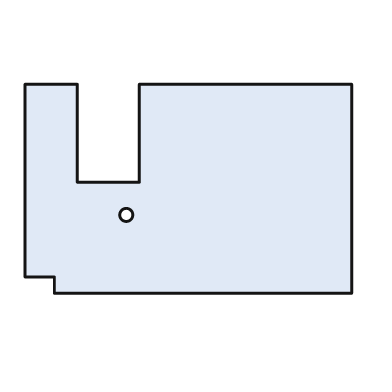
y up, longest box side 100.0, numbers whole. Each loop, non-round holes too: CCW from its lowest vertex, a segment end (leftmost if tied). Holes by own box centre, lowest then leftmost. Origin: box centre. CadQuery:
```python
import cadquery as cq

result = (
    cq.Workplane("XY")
    .moveTo(-41.0, -32.0)
    .lineTo(50.0, -32.0)
    .lineTo(50.0, 32.0)
    .lineTo(-15.0, 32.0)
    .lineTo(-15.0, 2.0)
    .lineTo(-34.0, 2.0)
    .lineTo(-34.0, 32.0)
    .lineTo(-50.0, 32.0)
    .lineTo(-50.0, -27.0)
    .lineTo(-41.0, -27.0)
    .close()
    .moveTo(-19.0, -8.0)
    .circle(2.0)
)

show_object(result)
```